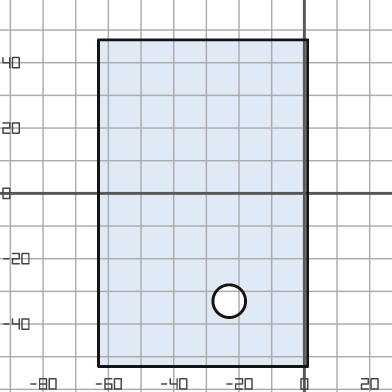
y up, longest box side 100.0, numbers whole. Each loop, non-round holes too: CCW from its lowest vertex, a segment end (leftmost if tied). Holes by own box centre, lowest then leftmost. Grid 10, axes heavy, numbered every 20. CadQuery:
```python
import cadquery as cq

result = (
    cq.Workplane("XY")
    .moveTo(-63.0, -53.0)
    .lineTo(1.0, -53.0)
    .lineTo(1.0, 47.0)
    .lineTo(-63.0, 47.0)
    .close()
    .moveTo(-23.0, -33.0)
    .circle(5.0)
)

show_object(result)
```